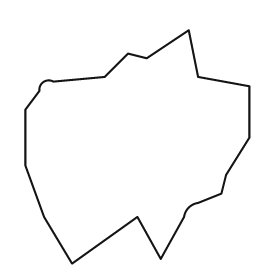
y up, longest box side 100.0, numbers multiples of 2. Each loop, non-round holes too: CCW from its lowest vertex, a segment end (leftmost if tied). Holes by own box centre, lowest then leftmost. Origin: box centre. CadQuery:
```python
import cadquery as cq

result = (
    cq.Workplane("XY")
    .moveTo(-28.0, -50.0)
    .lineTo(0.0, -30.0)
    .lineTo(10.0, -48.0)
    .lineTo(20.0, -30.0)
    .threePointArc((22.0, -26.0), (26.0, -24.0))
    .lineTo(36.0, -20.0)
    .lineTo(38.0, -12.0)
    .lineTo(48.0, 4.0)
    .lineTo(48.0, 26.0)
    .lineTo(26.0, 30.0)
    .lineTo(22.0, 50.0)
    .lineTo(4.0, 38.0)
    .lineTo(-4.0, 40.0)
    .lineTo(-14.0, 30.0)
    .lineTo(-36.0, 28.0)
    .threePointArc((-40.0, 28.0), (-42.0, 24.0))
    .lineTo(-48.0, 16.0)
    .lineTo(-48.0, -8.0)
    .lineTo(-40.0, -30.0)
    .close()
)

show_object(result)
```